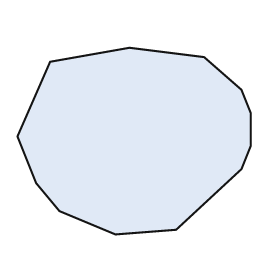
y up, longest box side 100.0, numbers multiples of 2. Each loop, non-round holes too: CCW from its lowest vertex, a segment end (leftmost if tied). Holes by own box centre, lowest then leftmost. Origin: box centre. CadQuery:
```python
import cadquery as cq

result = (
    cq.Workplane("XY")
    .moveTo(-8.0, -40.0)
    .lineTo(18.0, -38.0)
    .lineTo(46.0, -12.0)
    .lineTo(50.0, -2.0)
    .lineTo(50.0, 12.0)
    .lineTo(46.0, 22.0)
    .lineTo(30.0, 36.0)
    .lineTo(-2.0, 40.0)
    .lineTo(-36.0, 34.0)
    .lineTo(-50.0, 2.0)
    .lineTo(-42.0, -18.0)
    .lineTo(-32.0, -30.0)
    .close()
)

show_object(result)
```